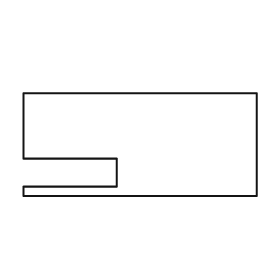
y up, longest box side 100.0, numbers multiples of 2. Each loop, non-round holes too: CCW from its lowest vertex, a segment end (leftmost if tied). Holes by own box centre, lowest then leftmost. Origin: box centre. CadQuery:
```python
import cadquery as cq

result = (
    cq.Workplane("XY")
    .moveTo(-50.0, -22.0)
    .lineTo(50.0, -22.0)
    .lineTo(50.0, 22.0)
    .lineTo(-50.0, 22.0)
    .lineTo(-50.0, -6.0)
    .lineTo(-10.0, -6.0)
    .lineTo(-10.0, -18.0)
    .lineTo(-50.0, -18.0)
    .close()
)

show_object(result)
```